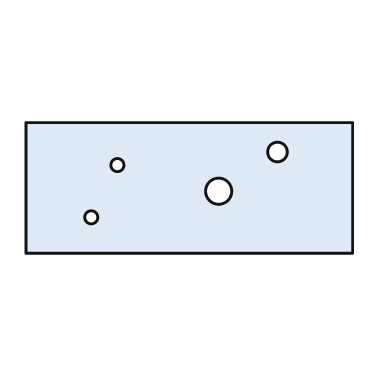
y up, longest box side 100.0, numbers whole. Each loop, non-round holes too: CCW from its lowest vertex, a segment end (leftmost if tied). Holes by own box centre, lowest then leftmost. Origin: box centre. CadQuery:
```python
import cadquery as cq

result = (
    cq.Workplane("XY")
    .moveTo(-50.0, -20.0)
    .lineTo(50.0, -20.0)
    .lineTo(50.0, 20.0)
    .lineTo(-50.0, 20.0)
    .close()
    .moveTo(-30.0, -9.0)
    .circle(2.0)
    .moveTo(9.0, -1.0)
    .circle(4.0)
    .moveTo(-22.0, 7.0)
    .circle(2.0)
    .moveTo(27.0, 11.0)
    .circle(3.0)
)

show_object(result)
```